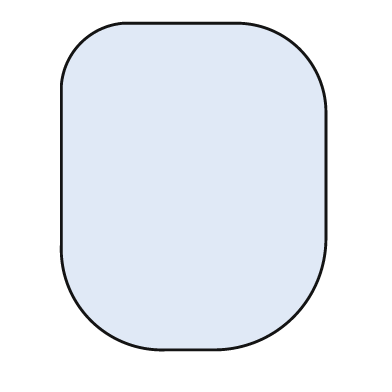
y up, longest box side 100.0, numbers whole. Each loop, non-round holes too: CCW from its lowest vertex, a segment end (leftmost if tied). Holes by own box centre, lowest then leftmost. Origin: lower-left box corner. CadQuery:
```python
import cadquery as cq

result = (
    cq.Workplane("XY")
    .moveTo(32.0, 0.0)
    .lineTo(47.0, 0.0)
    .threePointArc((71.0, 10.0), (81.0, 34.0))
    .lineTo(81.0, 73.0)
    .threePointArc((73.0, 92.0), (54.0, 100.0))
    .lineTo(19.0, 100.0)
    .threePointArc((6.0, 94.0), (0.0, 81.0))
    .lineTo(0.0, 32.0)
    .threePointArc((9.0, 9.0), (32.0, 0.0))
    .close()
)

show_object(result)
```